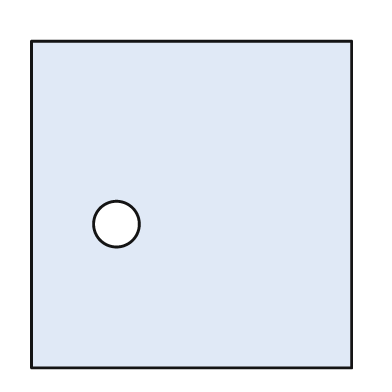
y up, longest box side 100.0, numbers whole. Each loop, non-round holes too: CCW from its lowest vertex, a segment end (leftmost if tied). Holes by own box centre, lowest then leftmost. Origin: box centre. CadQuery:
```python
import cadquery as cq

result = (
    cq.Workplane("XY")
    .moveTo(-49.0, -50.0)
    .lineTo(49.0, -50.0)
    .lineTo(49.0, 50.0)
    .lineTo(-49.0, 50.0)
    .close()
    .moveTo(-23.0, -6.0)
    .circle(7.0)
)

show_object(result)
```